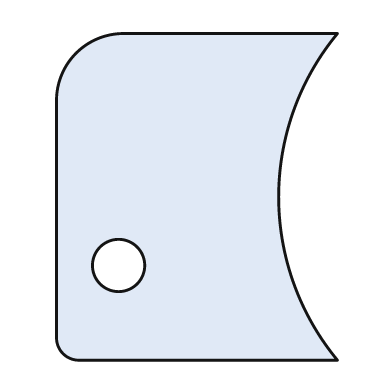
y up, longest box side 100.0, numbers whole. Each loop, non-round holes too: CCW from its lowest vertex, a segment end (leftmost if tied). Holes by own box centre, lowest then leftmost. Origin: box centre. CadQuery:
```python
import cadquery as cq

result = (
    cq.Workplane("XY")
    .moveTo(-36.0, -50.0)
    .lineTo(43.0, -50.0)
    .threePointArc((25.0, 0.0), (43.0, 50.0))
    .lineTo(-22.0, 50.0)
    .threePointArc((-37.0, 44.0), (-43.0, 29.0))
    .lineTo(-43.0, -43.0)
    .threePointArc((-41.0, -48.0), (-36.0, -50.0))
    .close()
    .moveTo(-24.0, -21.0)
    .circle(8.0)
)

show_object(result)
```